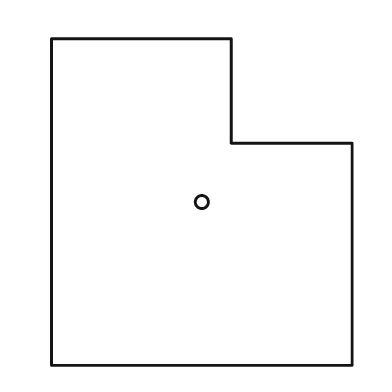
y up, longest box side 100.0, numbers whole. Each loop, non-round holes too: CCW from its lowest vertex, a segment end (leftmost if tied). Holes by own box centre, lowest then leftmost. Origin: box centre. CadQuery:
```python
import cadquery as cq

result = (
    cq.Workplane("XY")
    .moveTo(-46.0, -50.0)
    .lineTo(46.0, -50.0)
    .lineTo(46.0, 18.0)
    .lineTo(9.0, 18.0)
    .lineTo(9.0, 50.0)
    .lineTo(-46.0, 50.0)
    .close()
    .moveTo(0.0, 0.0)
    .circle(2.0)
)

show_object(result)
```